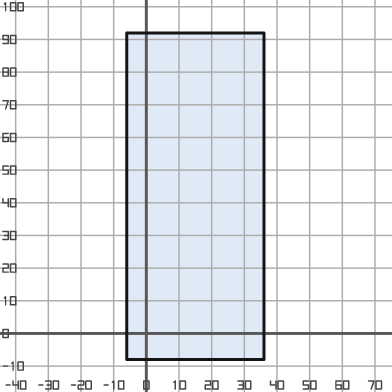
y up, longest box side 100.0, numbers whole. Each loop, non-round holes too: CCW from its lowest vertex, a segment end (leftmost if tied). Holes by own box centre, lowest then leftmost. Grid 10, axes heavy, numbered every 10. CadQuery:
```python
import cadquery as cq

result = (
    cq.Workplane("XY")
    .moveTo(-6.0, -8.0)
    .lineTo(36.0, -8.0)
    .lineTo(36.0, 92.0)
    .lineTo(-6.0, 92.0)
    .close()
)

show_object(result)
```